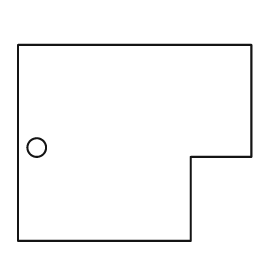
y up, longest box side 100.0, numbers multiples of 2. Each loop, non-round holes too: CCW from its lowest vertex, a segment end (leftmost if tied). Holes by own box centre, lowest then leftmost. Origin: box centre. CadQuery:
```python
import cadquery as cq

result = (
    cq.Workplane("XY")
    .moveTo(-50.0, -42.0)
    .lineTo(24.0, -42.0)
    .lineTo(24.0, -6.0)
    .lineTo(50.0, -6.0)
    .lineTo(50.0, 42.0)
    .lineTo(-50.0, 42.0)
    .close()
    .moveTo(-42.0, -2.0)
    .circle(4.0)
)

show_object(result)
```